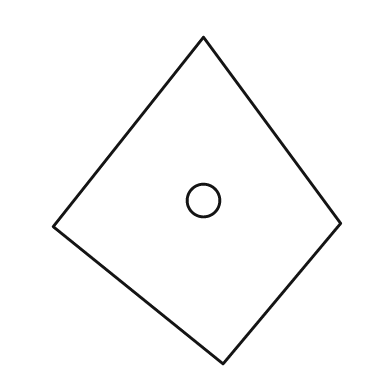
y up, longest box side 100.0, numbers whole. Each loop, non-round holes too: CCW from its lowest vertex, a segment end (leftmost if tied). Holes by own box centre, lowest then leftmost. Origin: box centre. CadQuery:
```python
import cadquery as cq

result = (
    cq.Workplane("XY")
    .moveTo(8.0, -50.0)
    .lineTo(44.0, -7.0)
    .lineTo(2.0, 50.0)
    .lineTo(-44.0, -8.0)
    .close()
    .moveTo(2.0, 0.0)
    .circle(5.0)
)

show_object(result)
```